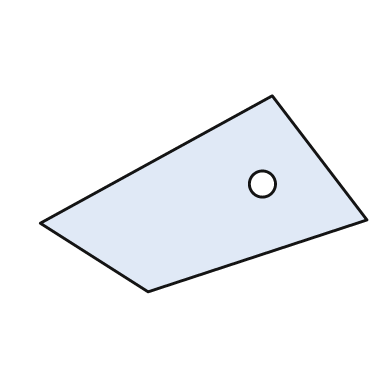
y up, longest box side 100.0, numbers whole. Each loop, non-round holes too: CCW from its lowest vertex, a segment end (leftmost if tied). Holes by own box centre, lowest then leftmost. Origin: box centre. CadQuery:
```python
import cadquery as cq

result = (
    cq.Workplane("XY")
    .moveTo(-17.0, -30.0)
    .lineTo(50.0, -8.0)
    .lineTo(21.0, 30.0)
    .lineTo(-50.0, -9.0)
    .close()
    .moveTo(18.0, 3.0)
    .circle(4.0)
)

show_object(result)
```